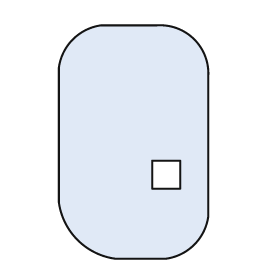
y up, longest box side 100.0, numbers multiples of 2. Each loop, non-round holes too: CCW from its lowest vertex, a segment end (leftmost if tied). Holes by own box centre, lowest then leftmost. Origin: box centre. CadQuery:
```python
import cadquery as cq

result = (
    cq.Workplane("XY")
    .moveTo(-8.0, -50.0)
    .lineTo(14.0, -50.0)
    .threePointArc((26.0, -44.0), (32.0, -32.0))
    .lineTo(32.0, 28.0)
    .threePointArc((26.0, 44.0), (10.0, 50.0))
    .lineTo(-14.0, 50.0)
    .threePointArc((-26.0, 44.0), (-32.0, 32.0))
    .lineTo(-32.0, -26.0)
    .threePointArc((-24.0, -42.0), (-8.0, -50.0))
    .close()
    .moveTo(8.0, -20.0)
    .lineTo(20.0, -20.0)
    .lineTo(20.0, -8.0)
    .lineTo(8.0, -8.0)
    .close()
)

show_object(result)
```